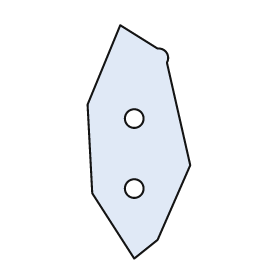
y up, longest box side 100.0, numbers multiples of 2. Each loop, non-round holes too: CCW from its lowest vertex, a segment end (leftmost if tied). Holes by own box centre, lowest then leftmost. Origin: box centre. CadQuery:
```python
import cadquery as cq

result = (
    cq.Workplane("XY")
    .moveTo(-2.0, -50.0)
    .lineTo(8.0, -42.0)
    .lineTo(22.0, -10.0)
    .lineTo(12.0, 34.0)
    .threePointArc((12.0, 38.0), (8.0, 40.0))
    .lineTo(-8.0, 50.0)
    .lineTo(-22.0, 16.0)
    .lineTo(-20.0, -22.0)
    .close()
    .moveTo(-2.0, -20.0)
    .circle(4.0)
    .moveTo(-2.0, 10.0)
    .circle(4.0)
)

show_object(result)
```